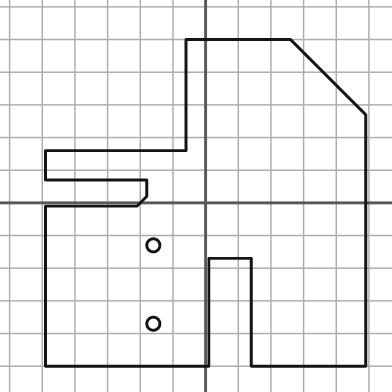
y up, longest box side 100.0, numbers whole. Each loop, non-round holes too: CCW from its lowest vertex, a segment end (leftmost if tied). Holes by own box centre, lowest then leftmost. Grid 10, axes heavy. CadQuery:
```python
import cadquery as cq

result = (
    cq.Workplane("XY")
    .moveTo(-49.0, -50.0)
    .lineTo(1.0, -50.0)
    .lineTo(1.0, -17.0)
    .lineTo(14.0, -17.0)
    .lineTo(14.0, -50.0)
    .lineTo(49.0, -50.0)
    .lineTo(49.0, 27.0)
    .lineTo(26.0, 50.0)
    .lineTo(-6.0, 50.0)
    .lineTo(-6.0, 16.0)
    .lineTo(-49.0, 16.0)
    .lineTo(-49.0, 7.0)
    .lineTo(-18.0, 7.0)
    .lineTo(-18.0, 2.0)
    .lineTo(-21.0, -1.0)
    .lineTo(-49.0, -1.0)
    .close()
    .moveTo(-16.0, -37.0)
    .circle(2.0)
    .moveTo(-16.0, -13.0)
    .circle(2.0)
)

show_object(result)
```